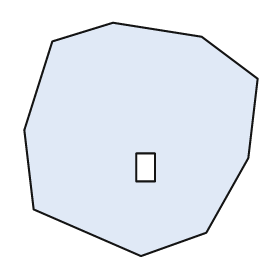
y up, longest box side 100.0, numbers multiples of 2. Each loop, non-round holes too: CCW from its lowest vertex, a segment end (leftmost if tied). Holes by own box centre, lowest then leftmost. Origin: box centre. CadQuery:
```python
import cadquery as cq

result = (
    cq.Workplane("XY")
    .moveTo(0.0, -50.0)
    .lineTo(28.0, -40.0)
    .lineTo(46.0, -8.0)
    .lineTo(50.0, 26.0)
    .lineTo(26.0, 44.0)
    .lineTo(-12.0, 50.0)
    .lineTo(-38.0, 42.0)
    .lineTo(-50.0, 4.0)
    .lineTo(-46.0, -30.0)
    .close()
    .moveTo(-2.0, -18.0)
    .lineTo(6.0, -18.0)
    .lineTo(6.0, -6.0)
    .lineTo(-2.0, -6.0)
    .close()
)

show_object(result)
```